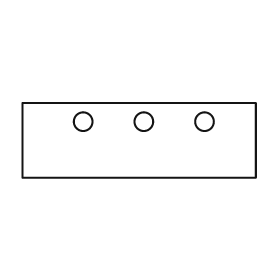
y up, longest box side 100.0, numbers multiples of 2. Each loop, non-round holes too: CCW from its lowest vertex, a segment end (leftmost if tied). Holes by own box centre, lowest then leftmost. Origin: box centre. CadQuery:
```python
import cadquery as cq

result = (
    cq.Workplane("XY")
    .moveTo(-50.0, -16.0)
    .lineTo(50.0, -16.0)
    .lineTo(50.0, 16.0)
    .lineTo(-50.0, 16.0)
    .close()
    .moveTo(-24.0, 8.0)
    .circle(4.0)
    .moveTo(2.0, 8.0)
    .circle(4.0)
    .moveTo(28.0, 8.0)
    .circle(4.0)
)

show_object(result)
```